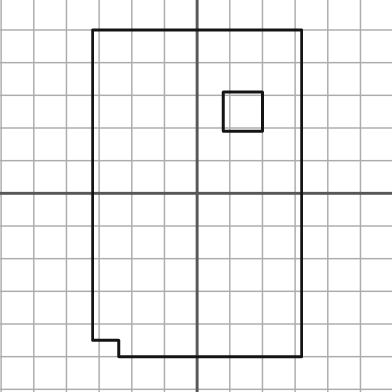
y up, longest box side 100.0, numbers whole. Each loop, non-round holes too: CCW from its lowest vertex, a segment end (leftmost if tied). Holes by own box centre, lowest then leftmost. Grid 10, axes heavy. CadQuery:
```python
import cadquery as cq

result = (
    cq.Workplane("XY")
    .moveTo(-24.0, -50.0)
    .lineTo(32.0, -50.0)
    .lineTo(32.0, 50.0)
    .lineTo(-32.0, 50.0)
    .lineTo(-32.0, -45.0)
    .lineTo(-24.0, -45.0)
    .close()
    .moveTo(8.0, 19.0)
    .lineTo(20.0, 19.0)
    .lineTo(20.0, 31.0)
    .lineTo(8.0, 31.0)
    .close()
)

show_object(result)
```